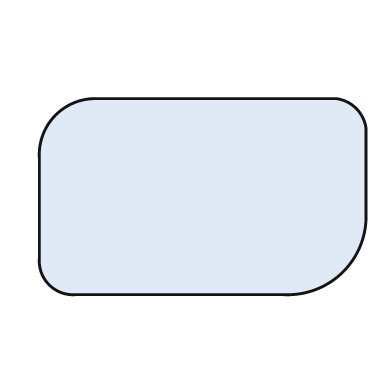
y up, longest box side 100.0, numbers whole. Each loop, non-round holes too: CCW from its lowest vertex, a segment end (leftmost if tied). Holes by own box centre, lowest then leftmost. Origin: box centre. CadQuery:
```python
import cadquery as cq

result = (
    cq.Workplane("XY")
    .moveTo(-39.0, -30.0)
    .lineTo(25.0, -30.0)
    .threePointArc((43.0, -23.0), (50.0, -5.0))
    .lineTo(50.0, 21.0)
    .threePointArc((47.0, 27.0), (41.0, 30.0))
    .lineTo(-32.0, 30.0)
    .threePointArc((-45.0, 25.0), (-50.0, 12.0))
    .lineTo(-50.0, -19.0)
    .threePointArc((-47.0, -27.0), (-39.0, -30.0))
    .close()
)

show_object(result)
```